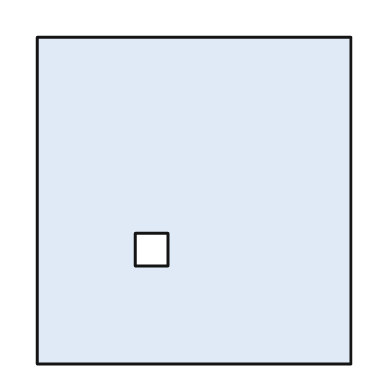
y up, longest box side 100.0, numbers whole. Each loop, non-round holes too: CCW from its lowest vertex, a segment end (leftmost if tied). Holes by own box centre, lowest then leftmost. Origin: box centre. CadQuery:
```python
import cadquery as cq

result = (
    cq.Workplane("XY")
    .moveTo(-48.0, -50.0)
    .lineTo(48.0, -50.0)
    .lineTo(48.0, 50.0)
    .lineTo(-48.0, 50.0)
    .close()
    .moveTo(-18.0, -20.0)
    .lineTo(-8.0, -20.0)
    .lineTo(-8.0, -10.0)
    .lineTo(-18.0, -10.0)
    .close()
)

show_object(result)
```